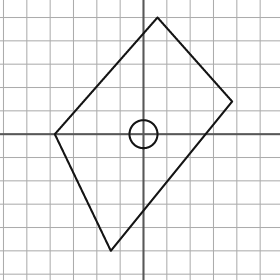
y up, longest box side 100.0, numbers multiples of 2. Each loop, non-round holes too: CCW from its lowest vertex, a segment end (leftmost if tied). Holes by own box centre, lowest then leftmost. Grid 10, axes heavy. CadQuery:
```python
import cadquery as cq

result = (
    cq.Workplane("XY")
    .moveTo(-14.0, -50.0)
    .lineTo(38.0, 14.0)
    .lineTo(6.0, 50.0)
    .lineTo(-38.0, 0.0)
    .close()
    .moveTo(0.0, 0.0)
    .circle(6.0)
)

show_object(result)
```